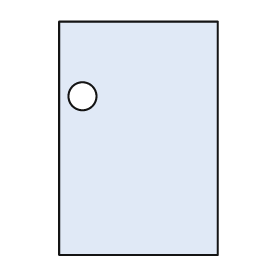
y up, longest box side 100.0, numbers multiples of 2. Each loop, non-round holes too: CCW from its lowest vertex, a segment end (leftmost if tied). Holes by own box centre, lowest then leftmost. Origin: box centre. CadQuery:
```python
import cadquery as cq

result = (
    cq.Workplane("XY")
    .moveTo(-34.0, -50.0)
    .lineTo(34.0, -50.0)
    .lineTo(34.0, 50.0)
    .lineTo(-34.0, 50.0)
    .close()
    .moveTo(-24.0, 18.0)
    .circle(6.0)
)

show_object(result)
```